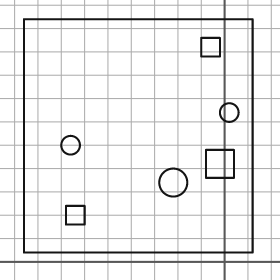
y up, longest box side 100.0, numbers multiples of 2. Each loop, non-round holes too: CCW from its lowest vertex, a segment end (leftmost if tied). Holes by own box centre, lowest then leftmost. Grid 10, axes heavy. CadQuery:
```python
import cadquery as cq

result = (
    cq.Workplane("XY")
    .moveTo(-86.0, 4.0)
    .lineTo(12.0, 4.0)
    .lineTo(12.0, 104.0)
    .lineTo(-86.0, 104.0)
    .close()
    .moveTo(-68.0, 16.0)
    .lineTo(-60.0, 16.0)
    .lineTo(-60.0, 24.0)
    .lineTo(-68.0, 24.0)
    .close()
    .moveTo(-22.0, 34.0)
    .circle(6.0)
    .moveTo(-8.0, 36.0)
    .lineTo(4.0, 36.0)
    .lineTo(4.0, 48.0)
    .lineTo(-8.0, 48.0)
    .close()
    .moveTo(-66.0, 50.0)
    .circle(4.0)
    .moveTo(2.0, 64.0)
    .circle(4.0)
    .moveTo(-10.0, 88.0)
    .lineTo(-2.0, 88.0)
    .lineTo(-2.0, 96.0)
    .lineTo(-10.0, 96.0)
    .close()
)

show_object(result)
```